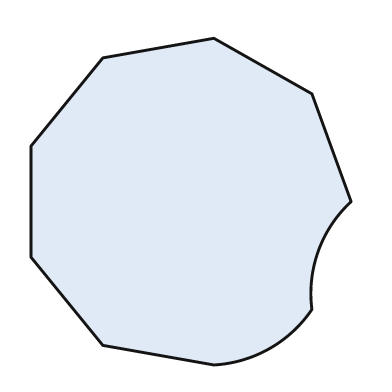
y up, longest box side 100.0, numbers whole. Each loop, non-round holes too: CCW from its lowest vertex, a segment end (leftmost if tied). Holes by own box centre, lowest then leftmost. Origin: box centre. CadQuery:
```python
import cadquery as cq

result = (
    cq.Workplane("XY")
    .moveTo(7.0, -50.0)
    .threePointArc((24.0, -45.0), (37.0, -33.0))
    .threePointArc((39.0, -15.0), (49.0, 0.0))
    .lineTo(37.0, 33.0)
    .lineTo(7.0, 50.0)
    .lineTo(-27.0, 44.0)
    .lineTo(-49.0, 17.0)
    .lineTo(-49.0, -17.0)
    .lineTo(-27.0, -44.0)
    .close()
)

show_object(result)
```